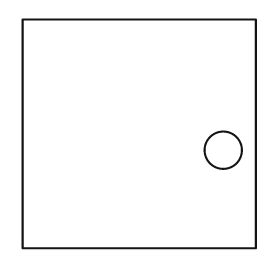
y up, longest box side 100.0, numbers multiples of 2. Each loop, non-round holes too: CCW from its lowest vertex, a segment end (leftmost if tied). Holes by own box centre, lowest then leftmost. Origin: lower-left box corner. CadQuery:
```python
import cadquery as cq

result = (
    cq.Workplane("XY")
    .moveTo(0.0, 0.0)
    .lineTo(100.0, 0.0)
    .lineTo(100.0, 98.0)
    .lineTo(0.0, 98.0)
    .close()
    .moveTo(86.0, 42.0)
    .circle(8.0)
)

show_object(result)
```